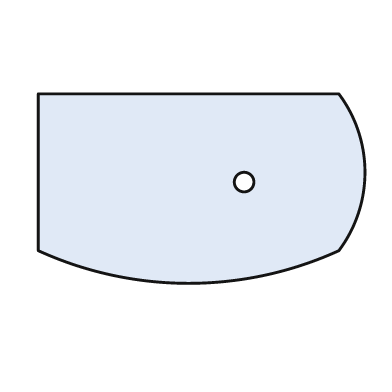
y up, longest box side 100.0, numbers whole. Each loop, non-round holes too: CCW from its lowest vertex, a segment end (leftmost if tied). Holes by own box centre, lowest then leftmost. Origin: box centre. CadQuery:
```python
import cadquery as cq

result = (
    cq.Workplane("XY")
    .moveTo(-50.0, -19.0)
    .threePointArc((-4.0, -29.0), (42.0, -19.0))
    .threePointArc((50.0, 5.0), (42.0, 29.0))
    .lineTo(-50.0, 29.0)
    .close()
    .moveTo(13.0, 2.0)
    .circle(3.0)
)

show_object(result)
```